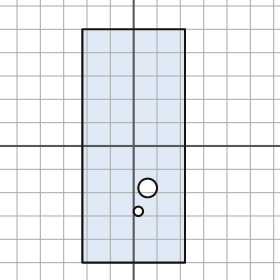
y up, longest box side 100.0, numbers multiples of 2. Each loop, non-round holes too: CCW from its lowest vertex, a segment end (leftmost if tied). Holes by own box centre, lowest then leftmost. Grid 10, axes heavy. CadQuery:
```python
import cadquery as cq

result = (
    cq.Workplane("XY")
    .moveTo(-22.0, -50.0)
    .lineTo(22.0, -50.0)
    .lineTo(22.0, 50.0)
    .lineTo(-22.0, 50.0)
    .close()
    .moveTo(2.0, -28.0)
    .circle(2.0)
    .moveTo(6.0, -18.0)
    .circle(4.0)
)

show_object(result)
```